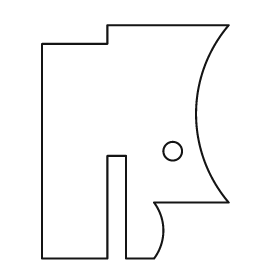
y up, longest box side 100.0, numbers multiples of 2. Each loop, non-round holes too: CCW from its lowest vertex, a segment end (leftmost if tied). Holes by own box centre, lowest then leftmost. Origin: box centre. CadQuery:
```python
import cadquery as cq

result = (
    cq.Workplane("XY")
    .moveTo(-40.0, -50.0)
    .lineTo(-12.0, -50.0)
    .lineTo(-12.0, -6.0)
    .lineTo(-4.0, -6.0)
    .lineTo(-4.0, -50.0)
    .lineTo(8.0, -50.0)
    .threePointArc((12.0, -38.0), (8.0, -26.0))
    .lineTo(40.0, -26.0)
    .threePointArc((26.0, 12.0), (40.0, 50.0))
    .lineTo(-12.0, 50.0)
    .lineTo(-12.0, 42.0)
    .lineTo(-40.0, 42.0)
    .close()
    .moveTo(16.0, -4.0)
    .circle(4.0)
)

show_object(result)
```